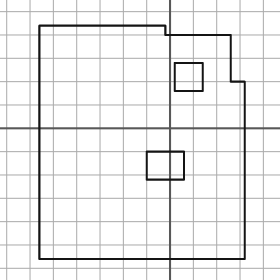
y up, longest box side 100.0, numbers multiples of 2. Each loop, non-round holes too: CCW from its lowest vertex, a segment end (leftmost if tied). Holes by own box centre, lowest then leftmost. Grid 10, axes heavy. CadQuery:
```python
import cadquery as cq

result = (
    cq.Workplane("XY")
    .moveTo(-56.0, -56.0)
    .lineTo(32.0, -56.0)
    .lineTo(32.0, 20.0)
    .lineTo(26.0, 20.0)
    .lineTo(26.0, 40.0)
    .lineTo(-2.0, 40.0)
    .lineTo(-2.0, 44.0)
    .lineTo(-56.0, 44.0)
    .close()
    .moveTo(-10.0, -22.0)
    .lineTo(6.0, -22.0)
    .lineTo(6.0, -10.0)
    .lineTo(-10.0, -10.0)
    .close()
    .moveTo(2.0, 16.0)
    .lineTo(14.0, 16.0)
    .lineTo(14.0, 28.0)
    .lineTo(2.0, 28.0)
    .close()
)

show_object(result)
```